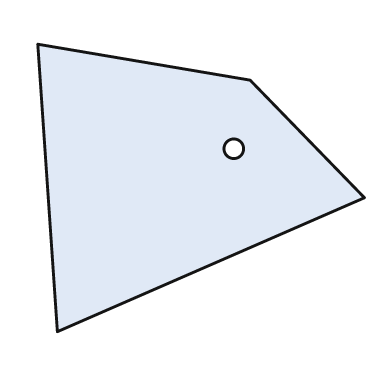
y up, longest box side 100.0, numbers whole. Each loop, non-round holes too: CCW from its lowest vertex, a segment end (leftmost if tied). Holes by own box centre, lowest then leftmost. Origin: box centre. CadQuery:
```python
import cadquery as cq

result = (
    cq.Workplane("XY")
    .moveTo(-44.0, -44.0)
    .lineTo(50.0, -3.0)
    .lineTo(15.0, 33.0)
    .lineTo(-50.0, 44.0)
    .close()
    .moveTo(10.0, 12.0)
    .circle(3.0)
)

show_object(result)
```